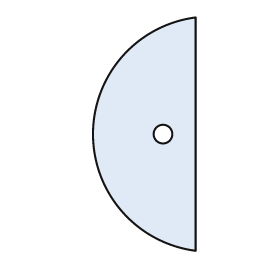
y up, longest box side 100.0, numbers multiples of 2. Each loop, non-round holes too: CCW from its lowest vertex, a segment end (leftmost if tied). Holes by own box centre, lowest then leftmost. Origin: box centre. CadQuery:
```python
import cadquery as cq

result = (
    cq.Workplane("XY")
    .moveTo(22.0, -50.0)
    .lineTo(22.0, 50.0)
    .threePointArc((-22.0, 0.0), (22.0, -50.0))
    .close()
    .moveTo(8.0, 0.0)
    .circle(4.0)
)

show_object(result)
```